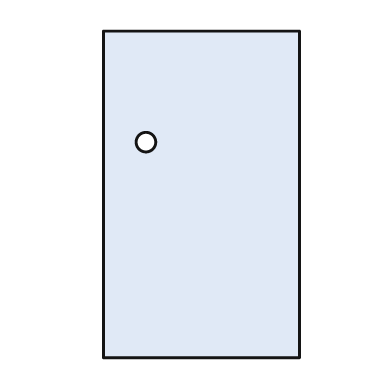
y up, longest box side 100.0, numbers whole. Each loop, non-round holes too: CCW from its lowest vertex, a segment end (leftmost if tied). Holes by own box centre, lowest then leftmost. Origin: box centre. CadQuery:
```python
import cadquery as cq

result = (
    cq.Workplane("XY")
    .moveTo(-30.0, -50.0)
    .lineTo(30.0, -50.0)
    .lineTo(30.0, 50.0)
    .lineTo(-30.0, 50.0)
    .close()
    .moveTo(-17.0, 16.0)
    .circle(3.0)
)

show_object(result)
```